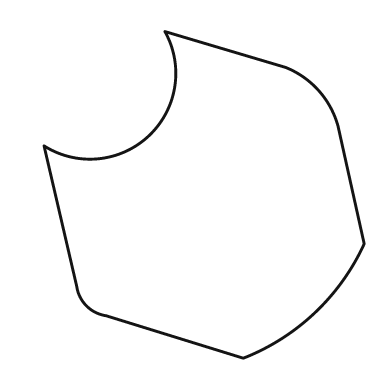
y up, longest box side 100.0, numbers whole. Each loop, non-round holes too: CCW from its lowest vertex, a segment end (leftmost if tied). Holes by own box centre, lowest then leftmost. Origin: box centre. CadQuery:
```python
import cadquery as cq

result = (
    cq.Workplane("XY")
    .moveTo(12.0, -50.0)
    .threePointArc((34.0, -36.0), (49.0, -15.0))
    .lineTo(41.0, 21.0)
    .threePointArc((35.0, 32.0), (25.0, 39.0))
    .lineTo(-12.0, 50.0)
    .threePointArc((-17.0, 18.0), (-49.0, 15.0))
    .lineTo(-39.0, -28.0)
    .threePointArc((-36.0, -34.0), (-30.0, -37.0))
    .close()
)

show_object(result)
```